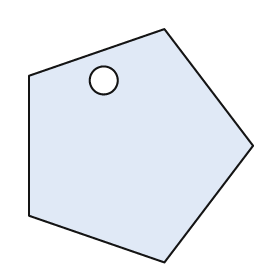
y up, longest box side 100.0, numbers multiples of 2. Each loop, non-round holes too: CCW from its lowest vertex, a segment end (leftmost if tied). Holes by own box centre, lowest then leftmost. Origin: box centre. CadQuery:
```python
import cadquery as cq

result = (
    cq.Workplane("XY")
    .moveTo(10.0, -50.0)
    .lineTo(48.0, 0.0)
    .lineTo(10.0, 50.0)
    .lineTo(-48.0, 30.0)
    .lineTo(-48.0, -30.0)
    .close()
    .moveTo(-16.0, 28.0)
    .circle(6.0)
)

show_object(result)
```